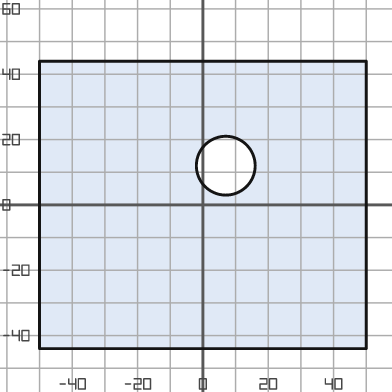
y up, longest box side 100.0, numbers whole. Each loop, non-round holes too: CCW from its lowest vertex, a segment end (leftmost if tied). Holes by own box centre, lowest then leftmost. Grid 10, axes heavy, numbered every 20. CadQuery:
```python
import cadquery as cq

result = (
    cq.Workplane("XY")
    .moveTo(-50.0, -44.0)
    .lineTo(50.0, -44.0)
    .lineTo(50.0, 44.0)
    .lineTo(-50.0, 44.0)
    .close()
    .moveTo(7.0, 12.0)
    .circle(9.0)
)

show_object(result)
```